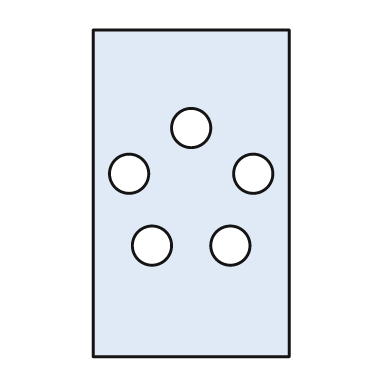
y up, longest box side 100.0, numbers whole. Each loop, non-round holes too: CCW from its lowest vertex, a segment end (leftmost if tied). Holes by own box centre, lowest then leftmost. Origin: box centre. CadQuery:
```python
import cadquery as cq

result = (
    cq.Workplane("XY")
    .moveTo(-30.0, -50.0)
    .lineTo(30.0, -50.0)
    .lineTo(30.0, 50.0)
    .lineTo(-30.0, 50.0)
    .close()
    .moveTo(-12.0, -16.0)
    .circle(6.0)
    .moveTo(12.0, -16.0)
    .circle(6.0)
    .moveTo(-19.0, 6.0)
    .circle(6.0)
    .moveTo(19.0, 6.0)
    .circle(6.0)
    .moveTo(0.0, 20.0)
    .circle(6.0)
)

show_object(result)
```